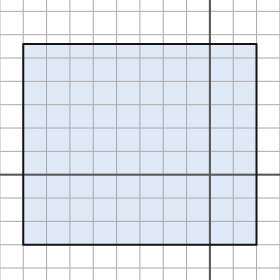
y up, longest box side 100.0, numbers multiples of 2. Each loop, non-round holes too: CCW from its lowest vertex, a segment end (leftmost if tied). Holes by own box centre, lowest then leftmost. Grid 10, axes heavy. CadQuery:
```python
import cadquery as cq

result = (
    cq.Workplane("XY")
    .moveTo(-80.0, -30.0)
    .lineTo(20.0, -30.0)
    .lineTo(20.0, 56.0)
    .lineTo(-80.0, 56.0)
    .close()
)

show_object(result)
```